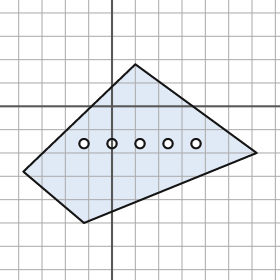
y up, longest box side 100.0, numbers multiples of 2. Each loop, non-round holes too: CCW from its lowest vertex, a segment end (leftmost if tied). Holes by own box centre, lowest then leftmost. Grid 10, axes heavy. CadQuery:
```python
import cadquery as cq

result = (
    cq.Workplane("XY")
    .moveTo(-12.0, -50.0)
    .lineTo(62.0, -20.0)
    .lineTo(10.0, 18.0)
    .lineTo(-38.0, -28.0)
    .close()
    .moveTo(-12.0, -16.0)
    .circle(2.0)
    .moveTo(0.0, -16.0)
    .circle(2.0)
    .moveTo(12.0, -16.0)
    .circle(2.0)
    .moveTo(24.0, -16.0)
    .circle(2.0)
    .moveTo(36.0, -16.0)
    .circle(2.0)
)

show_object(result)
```